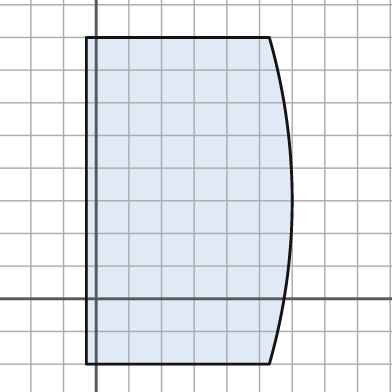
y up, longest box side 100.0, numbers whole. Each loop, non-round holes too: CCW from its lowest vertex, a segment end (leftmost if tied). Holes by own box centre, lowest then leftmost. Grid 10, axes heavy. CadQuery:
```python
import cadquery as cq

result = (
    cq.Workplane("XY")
    .moveTo(-3.0, -20.0)
    .lineTo(53.0, -20.0)
    .threePointArc((60.0, 30.0), (53.0, 80.0))
    .lineTo(-3.0, 80.0)
    .close()
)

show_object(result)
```